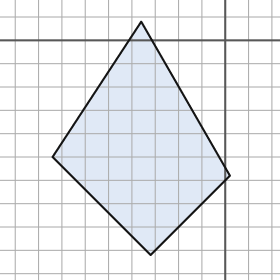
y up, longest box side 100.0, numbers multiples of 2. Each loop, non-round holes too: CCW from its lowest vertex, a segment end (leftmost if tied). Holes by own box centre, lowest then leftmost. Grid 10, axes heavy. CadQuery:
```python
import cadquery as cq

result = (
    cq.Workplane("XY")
    .moveTo(-32.0, -92.0)
    .lineTo(2.0, -58.0)
    .lineTo(-36.0, 8.0)
    .lineTo(-74.0, -50.0)
    .close()
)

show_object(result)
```